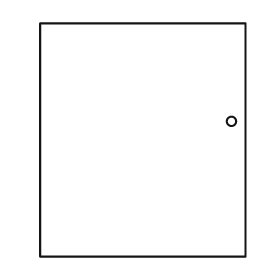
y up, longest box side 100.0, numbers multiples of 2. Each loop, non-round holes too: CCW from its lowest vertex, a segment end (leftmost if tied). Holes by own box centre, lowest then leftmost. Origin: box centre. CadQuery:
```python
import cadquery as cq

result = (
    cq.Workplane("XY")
    .moveTo(-44.0, -50.0)
    .lineTo(44.0, -50.0)
    .lineTo(44.0, 50.0)
    .lineTo(-44.0, 50.0)
    .close()
    .moveTo(38.0, 8.0)
    .circle(2.0)
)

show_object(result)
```